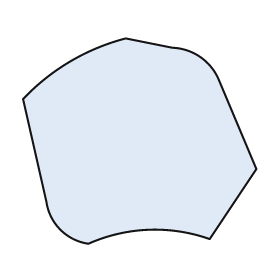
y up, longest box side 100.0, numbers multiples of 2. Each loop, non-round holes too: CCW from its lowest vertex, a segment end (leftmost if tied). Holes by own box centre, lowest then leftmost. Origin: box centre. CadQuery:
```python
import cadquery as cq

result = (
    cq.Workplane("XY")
    .moveTo(-22.0, -44.0)
    .threePointArc((4.0, -38.0), (30.0, -42.0))
    .lineTo(50.0, -12.0)
    .lineTo(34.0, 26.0)
    .threePointArc((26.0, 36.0), (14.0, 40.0))
    .lineTo(-6.0, 44.0)
    .threePointArc((-30.0, 34.0), (-50.0, 18.0))
    .lineTo(-40.0, -26.0)
    .threePointArc((-34.0, -38.0), (-22.0, -44.0))
    .close()
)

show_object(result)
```